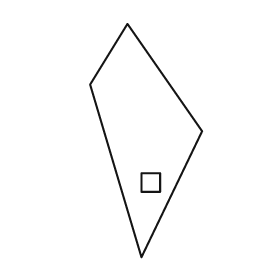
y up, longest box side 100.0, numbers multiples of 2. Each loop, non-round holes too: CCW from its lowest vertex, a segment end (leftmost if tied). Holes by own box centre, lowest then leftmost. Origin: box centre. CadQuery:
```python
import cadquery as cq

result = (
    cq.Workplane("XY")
    .moveTo(-2.0, -50.0)
    .lineTo(24.0, 4.0)
    .lineTo(-8.0, 50.0)
    .lineTo(-24.0, 24.0)
    .close()
    .moveTo(-2.0, -22.0)
    .lineTo(6.0, -22.0)
    .lineTo(6.0, -14.0)
    .lineTo(-2.0, -14.0)
    .close()
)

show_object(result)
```